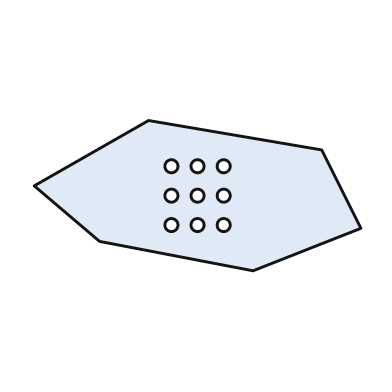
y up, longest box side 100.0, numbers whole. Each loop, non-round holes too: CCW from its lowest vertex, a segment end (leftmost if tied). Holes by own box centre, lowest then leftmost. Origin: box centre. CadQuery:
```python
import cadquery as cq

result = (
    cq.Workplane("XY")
    .moveTo(17.0, -23.0)
    .lineTo(50.0, -10.0)
    .lineTo(38.0, 14.0)
    .lineTo(-15.0, 23.0)
    .lineTo(-50.0, 3.0)
    .lineTo(-30.0, -14.0)
    .close()
    .moveTo(-8.0, -9.0)
    .circle(2.0)
    .moveTo(0.0, -9.0)
    .circle(2.0)
    .moveTo(8.0, -9.0)
    .circle(2.0)
    .moveTo(-8.0, 0.0)
    .circle(2.0)
    .moveTo(0.0, 0.0)
    .circle(2.0)
    .moveTo(8.0, 0.0)
    .circle(2.0)
    .moveTo(-8.0, 9.0)
    .circle(2.0)
    .moveTo(0.0, 9.0)
    .circle(2.0)
    .moveTo(8.0, 9.0)
    .circle(2.0)
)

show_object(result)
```